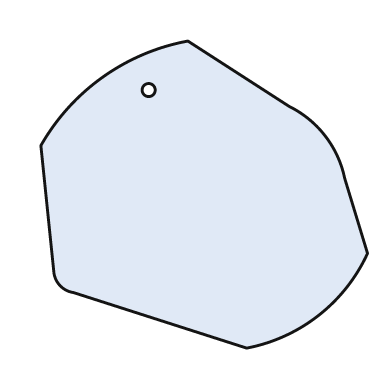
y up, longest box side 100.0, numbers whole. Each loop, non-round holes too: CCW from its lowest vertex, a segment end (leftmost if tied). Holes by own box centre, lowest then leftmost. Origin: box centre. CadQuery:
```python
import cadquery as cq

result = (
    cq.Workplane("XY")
    .moveTo(13.0, -47.0)
    .threePointArc((35.0, -37.0), (50.0, -18.0))
    .lineTo(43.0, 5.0)
    .threePointArc((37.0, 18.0), (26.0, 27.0))
    .lineTo(-5.0, 47.0)
    .threePointArc((-31.0, 36.0), (-50.0, 15.0))
    .lineTo(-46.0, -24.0)
    .threePointArc((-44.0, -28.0), (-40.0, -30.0))
    .close()
    .moveTo(-17.0, 32.0)
    .circle(2.0)
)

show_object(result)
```